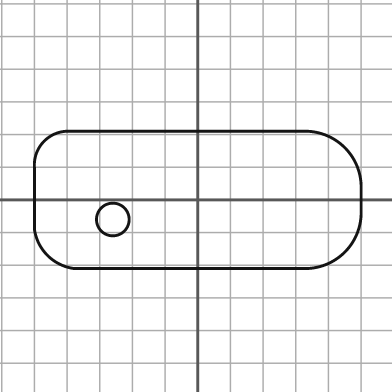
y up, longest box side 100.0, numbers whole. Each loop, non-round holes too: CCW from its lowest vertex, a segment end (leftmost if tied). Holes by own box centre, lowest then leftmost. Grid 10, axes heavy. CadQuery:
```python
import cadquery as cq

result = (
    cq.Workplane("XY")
    .moveTo(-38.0, -21.0)
    .lineTo(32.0, -21.0)
    .threePointArc((45.0, -16.0), (50.0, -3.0))
    .lineTo(50.0, 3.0)
    .threePointArc((45.0, 16.0), (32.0, 21.0))
    .lineTo(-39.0, 21.0)
    .threePointArc((-47.0, 18.0), (-50.0, 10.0))
    .lineTo(-50.0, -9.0)
    .threePointArc((-46.0, -17.0), (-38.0, -21.0))
    .close()
    .moveTo(-26.0, -6.0)
    .circle(5.0)
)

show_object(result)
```